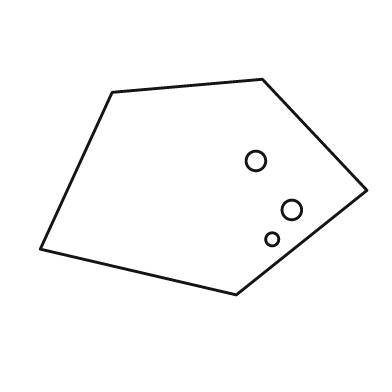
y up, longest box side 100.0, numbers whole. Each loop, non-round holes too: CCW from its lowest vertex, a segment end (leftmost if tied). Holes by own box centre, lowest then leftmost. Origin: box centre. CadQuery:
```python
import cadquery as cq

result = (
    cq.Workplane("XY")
    .moveTo(10.0, -33.0)
    .lineTo(50.0, -1.0)
    .lineTo(18.0, 33.0)
    .lineTo(-28.0, 29.0)
    .lineTo(-50.0, -19.0)
    .close()
    .moveTo(21.0, -16.0)
    .circle(2.0)
    .moveTo(27.0, -7.0)
    .circle(3.0)
    .moveTo(16.0, 8.0)
    .circle(3.0)
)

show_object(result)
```